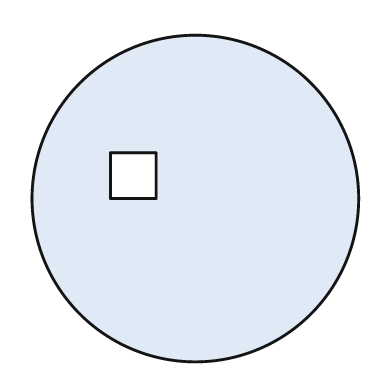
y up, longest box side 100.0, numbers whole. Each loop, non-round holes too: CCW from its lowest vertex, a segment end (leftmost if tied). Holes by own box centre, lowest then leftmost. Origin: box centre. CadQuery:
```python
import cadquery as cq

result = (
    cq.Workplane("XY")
    .moveTo(0.0, 0.0)
    .circle(50.0)
    .moveTo(-26.0, 0.0)
    .lineTo(-12.0, 0.0)
    .lineTo(-12.0, 14.0)
    .lineTo(-26.0, 14.0)
    .close()
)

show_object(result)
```